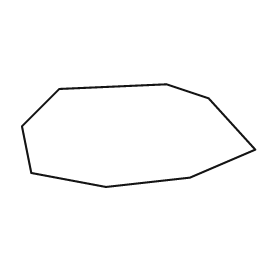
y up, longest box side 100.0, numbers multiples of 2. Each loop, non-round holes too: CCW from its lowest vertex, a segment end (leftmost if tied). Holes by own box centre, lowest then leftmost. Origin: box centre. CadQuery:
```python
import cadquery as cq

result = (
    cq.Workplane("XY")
    .moveTo(-14.0, -22.0)
    .lineTo(22.0, -18.0)
    .lineTo(50.0, -6.0)
    .lineTo(30.0, 16.0)
    .lineTo(12.0, 22.0)
    .lineTo(-34.0, 20.0)
    .lineTo(-50.0, 4.0)
    .lineTo(-46.0, -16.0)
    .close()
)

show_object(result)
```